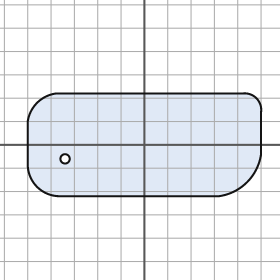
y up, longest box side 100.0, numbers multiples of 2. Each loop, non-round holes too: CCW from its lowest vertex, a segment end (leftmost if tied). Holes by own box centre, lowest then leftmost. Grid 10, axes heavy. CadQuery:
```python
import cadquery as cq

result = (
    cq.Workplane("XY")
    .moveTo(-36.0, -22.0)
    .lineTo(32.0, -22.0)
    .threePointArc((44.0, -16.0), (50.0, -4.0))
    .lineTo(50.0, 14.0)
    .threePointArc((48.0, 20.0), (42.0, 22.0))
    .lineTo(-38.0, 22.0)
    .threePointArc((-46.0, 18.0), (-50.0, 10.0))
    .lineTo(-50.0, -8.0)
    .threePointArc((-46.0, -18.0), (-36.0, -22.0))
    .close()
    .moveTo(-34.0, -6.0)
    .circle(2.0)
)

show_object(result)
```